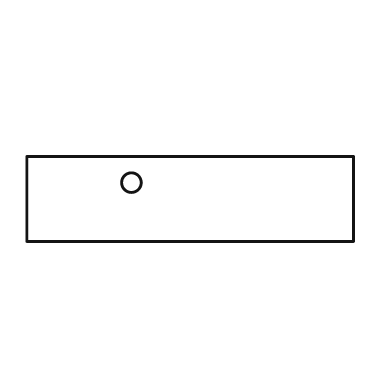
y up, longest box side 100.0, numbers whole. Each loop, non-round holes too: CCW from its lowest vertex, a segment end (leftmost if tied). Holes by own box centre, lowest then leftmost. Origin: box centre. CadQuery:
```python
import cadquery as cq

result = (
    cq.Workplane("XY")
    .moveTo(-50.0, -13.0)
    .lineTo(50.0, -13.0)
    .lineTo(50.0, 13.0)
    .lineTo(-50.0, 13.0)
    .close()
    .moveTo(-18.0, 5.0)
    .circle(3.0)
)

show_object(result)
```